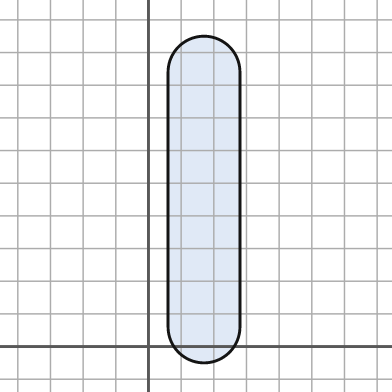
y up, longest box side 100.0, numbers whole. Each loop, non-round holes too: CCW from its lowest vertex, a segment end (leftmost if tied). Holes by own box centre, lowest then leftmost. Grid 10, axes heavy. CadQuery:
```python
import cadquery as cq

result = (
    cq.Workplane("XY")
    .moveTo(6.0, 6.0)
    .threePointArc((17.0, -5.0), (28.0, 6.0))
    .lineTo(28.0, 84.0)
    .threePointArc((17.0, 95.0), (6.0, 84.0))
    .close()
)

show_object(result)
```